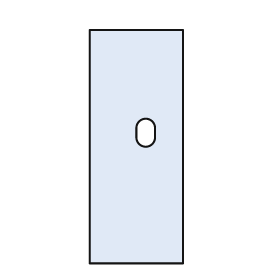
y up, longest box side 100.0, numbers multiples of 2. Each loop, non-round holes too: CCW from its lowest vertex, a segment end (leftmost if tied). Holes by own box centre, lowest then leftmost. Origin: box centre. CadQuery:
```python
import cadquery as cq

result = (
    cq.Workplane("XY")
    .moveTo(-20.0, -50.0)
    .lineTo(20.0, -50.0)
    .lineTo(20.0, 50.0)
    .lineTo(-20.0, 50.0)
    .close()
    .moveTo(0.0, 4.0)
    .threePointArc((4.0, 0.0), (8.0, 4.0))
    .lineTo(8.0, 8.0)
    .threePointArc((4.0, 12.0), (0.0, 8.0))
    .close()
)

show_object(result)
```